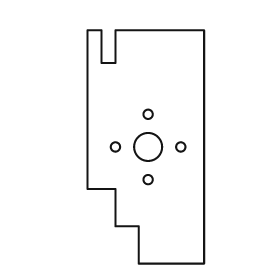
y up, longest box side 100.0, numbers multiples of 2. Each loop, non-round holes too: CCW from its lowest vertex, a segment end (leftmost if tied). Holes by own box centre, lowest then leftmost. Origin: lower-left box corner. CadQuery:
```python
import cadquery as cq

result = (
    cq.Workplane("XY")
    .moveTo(22.0, 0.0)
    .lineTo(50.0, 0.0)
    .lineTo(50.0, 100.0)
    .lineTo(12.0, 100.0)
    .lineTo(12.0, 86.0)
    .lineTo(6.0, 86.0)
    .lineTo(6.0, 100.0)
    .lineTo(0.0, 100.0)
    .lineTo(0.0, 32.0)
    .lineTo(12.0, 32.0)
    .lineTo(12.0, 16.0)
    .lineTo(22.0, 16.0)
    .close()
    .moveTo(26.0, 36.0)
    .circle(2.0)
    .moveTo(12.0, 50.0)
    .circle(2.0)
    .moveTo(26.0, 50.0)
    .circle(6.0)
    .moveTo(40.0, 50.0)
    .circle(2.0)
    .moveTo(26.0, 64.0)
    .circle(2.0)
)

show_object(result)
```